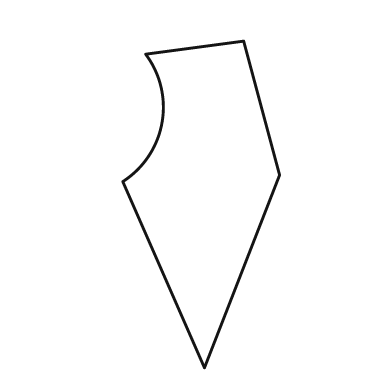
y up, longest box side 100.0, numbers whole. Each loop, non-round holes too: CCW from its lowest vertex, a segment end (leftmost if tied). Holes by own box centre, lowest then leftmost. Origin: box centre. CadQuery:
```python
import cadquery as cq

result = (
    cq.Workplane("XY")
    .moveTo(1.0, -50.0)
    .lineTo(24.0, 9.0)
    .lineTo(13.0, 50.0)
    .lineTo(-17.0, 46.0)
    .threePointArc((-12.0, 25.0), (-24.0, 7.0))
    .close()
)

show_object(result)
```